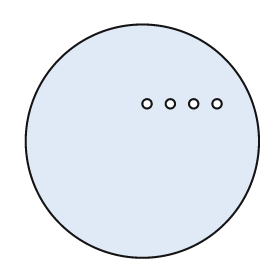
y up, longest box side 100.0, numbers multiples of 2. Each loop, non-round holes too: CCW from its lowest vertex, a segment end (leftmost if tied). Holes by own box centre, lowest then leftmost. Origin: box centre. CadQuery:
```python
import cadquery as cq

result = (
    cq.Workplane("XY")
    .moveTo(0.0, 0.0)
    .circle(50.0)
    .moveTo(2.0, 16.0)
    .circle(2.0)
    .moveTo(12.0, 16.0)
    .circle(2.0)
    .moveTo(22.0, 16.0)
    .circle(2.0)
    .moveTo(32.0, 16.0)
    .circle(2.0)
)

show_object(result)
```